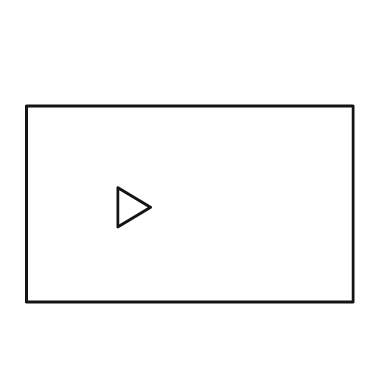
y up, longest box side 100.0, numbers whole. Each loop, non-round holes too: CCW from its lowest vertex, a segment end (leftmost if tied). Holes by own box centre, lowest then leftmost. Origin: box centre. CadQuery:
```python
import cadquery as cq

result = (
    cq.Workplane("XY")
    .moveTo(-50.0, -30.0)
    .lineTo(50.0, -30.0)
    .lineTo(50.0, 30.0)
    .lineTo(-50.0, 30.0)
    .close()
    .moveTo(-22.0, -7.0)
    .lineTo(-12.0, -1.0)
    .lineTo(-22.0, 5.0)
    .close()
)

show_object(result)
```